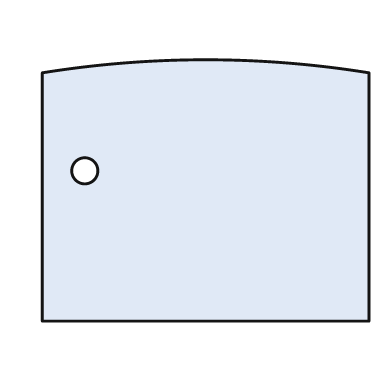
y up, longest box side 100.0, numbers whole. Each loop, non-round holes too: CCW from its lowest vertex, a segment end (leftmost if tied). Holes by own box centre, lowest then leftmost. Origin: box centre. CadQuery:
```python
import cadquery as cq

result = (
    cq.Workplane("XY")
    .moveTo(-50.0, -40.0)
    .lineTo(50.0, -40.0)
    .lineTo(50.0, 36.0)
    .threePointArc((0.0, 40.0), (-50.0, 36.0))
    .close()
    .moveTo(-37.0, 6.0)
    .circle(4.0)
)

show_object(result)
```